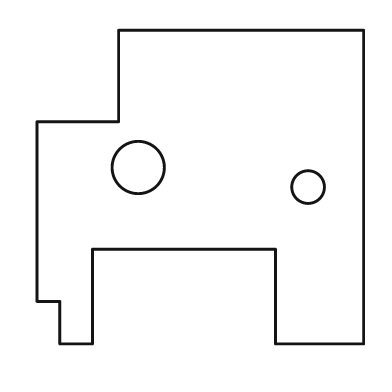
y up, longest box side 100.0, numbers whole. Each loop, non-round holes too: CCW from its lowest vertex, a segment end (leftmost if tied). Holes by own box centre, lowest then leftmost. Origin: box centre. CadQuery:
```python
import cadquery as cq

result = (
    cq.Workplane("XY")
    .moveTo(-43.0, -48.0)
    .lineTo(-33.0, -48.0)
    .lineTo(-33.0, -19.0)
    .lineTo(23.0, -19.0)
    .lineTo(23.0, -48.0)
    .lineTo(50.0, -48.0)
    .lineTo(50.0, 48.0)
    .lineTo(-25.0, 48.0)
    .lineTo(-25.0, 20.0)
    .lineTo(-50.0, 20.0)
    .lineTo(-50.0, -35.0)
    .lineTo(-43.0, -35.0)
    .close()
    .moveTo(33.0, 0.0)
    .circle(5.0)
    .moveTo(-19.0, 6.0)
    .circle(8.0)
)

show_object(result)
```